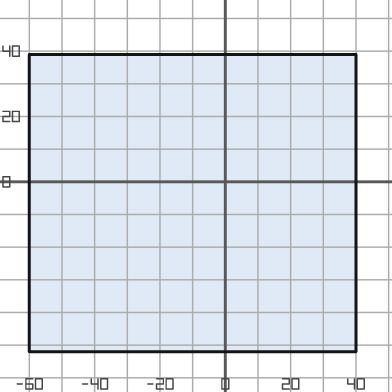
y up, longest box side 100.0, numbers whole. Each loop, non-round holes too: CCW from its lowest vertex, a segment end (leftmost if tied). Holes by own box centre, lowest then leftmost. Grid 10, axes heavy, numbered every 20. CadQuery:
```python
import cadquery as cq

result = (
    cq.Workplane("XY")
    .moveTo(-60.0, -52.0)
    .lineTo(40.0, -52.0)
    .lineTo(40.0, 39.0)
    .lineTo(-60.0, 39.0)
    .close()
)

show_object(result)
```